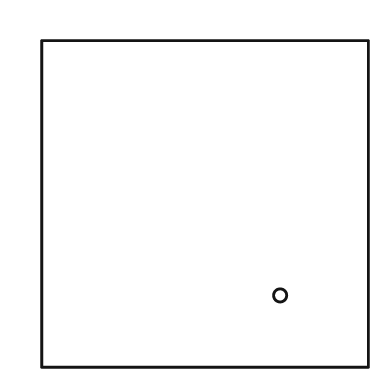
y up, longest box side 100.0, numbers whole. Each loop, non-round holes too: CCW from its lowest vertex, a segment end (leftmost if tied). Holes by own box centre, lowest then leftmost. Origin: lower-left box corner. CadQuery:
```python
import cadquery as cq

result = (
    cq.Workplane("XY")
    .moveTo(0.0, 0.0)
    .lineTo(100.0, 0.0)
    .lineTo(100.0, 100.0)
    .lineTo(0.0, 100.0)
    .close()
    .moveTo(73.0, 22.0)
    .circle(2.0)
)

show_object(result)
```